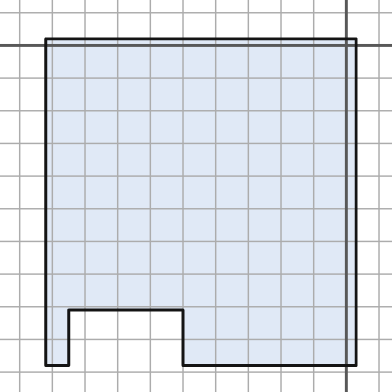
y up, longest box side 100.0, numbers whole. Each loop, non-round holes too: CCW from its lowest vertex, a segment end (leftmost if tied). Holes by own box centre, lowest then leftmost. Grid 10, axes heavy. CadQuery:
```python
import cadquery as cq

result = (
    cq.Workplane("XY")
    .moveTo(-92.0, -98.0)
    .lineTo(-85.0, -98.0)
    .lineTo(-85.0, -81.0)
    .lineTo(-50.0, -81.0)
    .lineTo(-50.0, -98.0)
    .lineTo(3.0, -98.0)
    .lineTo(3.0, 2.0)
    .lineTo(-92.0, 2.0)
    .close()
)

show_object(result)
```